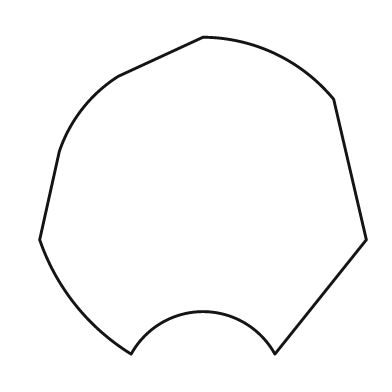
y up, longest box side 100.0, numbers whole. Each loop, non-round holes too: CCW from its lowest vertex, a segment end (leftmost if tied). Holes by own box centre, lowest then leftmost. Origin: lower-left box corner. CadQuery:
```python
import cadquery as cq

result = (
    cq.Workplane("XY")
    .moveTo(28.0, 0.0)
    .threePointArc((50.0, 13.0), (72.0, 0.0))
    .lineTo(100.0, 35.0)
    .lineTo(90.0, 78.0)
    .threePointArc((72.0, 92.0), (50.0, 97.0))
    .lineTo(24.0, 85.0)
    .threePointArc((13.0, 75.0), (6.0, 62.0))
    .lineTo(0.0, 35.0)
    .threePointArc((11.0, 15.0), (28.0, 0.0))
    .close()
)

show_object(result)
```